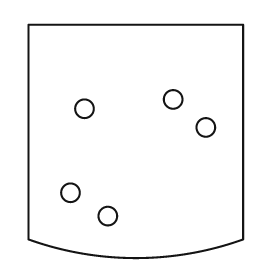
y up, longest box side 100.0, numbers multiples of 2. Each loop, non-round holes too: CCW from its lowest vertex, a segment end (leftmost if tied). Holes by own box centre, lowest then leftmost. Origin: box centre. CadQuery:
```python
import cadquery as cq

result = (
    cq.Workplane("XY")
    .moveTo(-46.0, -42.0)
    .threePointArc((0.0, -50.0), (46.0, -42.0))
    .lineTo(46.0, 50.0)
    .lineTo(-46.0, 50.0)
    .close()
    .moveTo(-12.0, -32.0)
    .circle(4.0)
    .moveTo(-28.0, -22.0)
    .circle(4.0)
    .moveTo(30.0, 6.0)
    .circle(4.0)
    .moveTo(-22.0, 14.0)
    .circle(4.0)
    .moveTo(16.0, 18.0)
    .circle(4.0)
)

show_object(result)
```